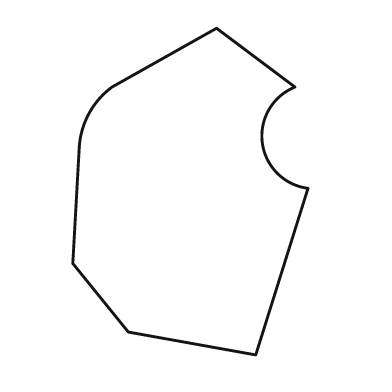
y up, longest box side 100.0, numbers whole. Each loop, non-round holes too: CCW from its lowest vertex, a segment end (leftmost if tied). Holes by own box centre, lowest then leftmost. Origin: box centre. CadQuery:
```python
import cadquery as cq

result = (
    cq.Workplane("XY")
    .moveTo(20.0, -50.0)
    .lineTo(36.0, 1.0)
    .threePointArc((22.0, 15.0), (32.0, 32.0))
    .lineTo(8.0, 50.0)
    .lineTo(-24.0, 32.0)
    .threePointArc((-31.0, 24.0), (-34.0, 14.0))
    .lineTo(-36.0, -22.0)
    .lineTo(-19.0, -43.0)
    .close()
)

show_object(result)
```